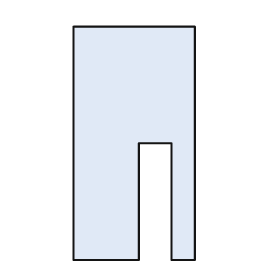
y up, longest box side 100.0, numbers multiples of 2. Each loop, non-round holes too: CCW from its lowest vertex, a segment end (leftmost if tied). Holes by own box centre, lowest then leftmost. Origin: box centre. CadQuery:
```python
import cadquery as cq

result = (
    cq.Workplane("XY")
    .moveTo(-26.0, -50.0)
    .lineTo(2.0, -50.0)
    .lineTo(2.0, 0.0)
    .lineTo(16.0, 0.0)
    .lineTo(16.0, -50.0)
    .lineTo(26.0, -50.0)
    .lineTo(26.0, 50.0)
    .lineTo(-26.0, 50.0)
    .close()
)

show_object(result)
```